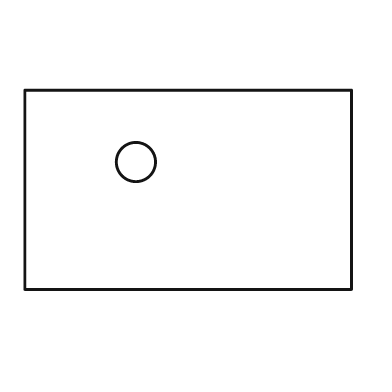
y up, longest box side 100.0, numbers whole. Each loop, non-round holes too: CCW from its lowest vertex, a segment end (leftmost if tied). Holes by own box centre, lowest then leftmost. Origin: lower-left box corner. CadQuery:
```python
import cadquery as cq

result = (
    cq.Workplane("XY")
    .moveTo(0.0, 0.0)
    .lineTo(100.0, 0.0)
    .lineTo(100.0, 61.0)
    .lineTo(0.0, 61.0)
    .close()
    .moveTo(34.0, 39.0)
    .circle(6.0)
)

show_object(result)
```